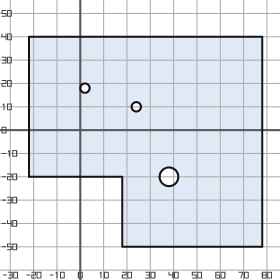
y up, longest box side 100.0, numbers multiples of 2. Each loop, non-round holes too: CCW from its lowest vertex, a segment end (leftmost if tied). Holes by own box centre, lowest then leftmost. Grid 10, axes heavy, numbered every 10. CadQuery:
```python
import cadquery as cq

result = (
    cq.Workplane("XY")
    .moveTo(18.0, -50.0)
    .lineTo(78.0, -50.0)
    .lineTo(78.0, 40.0)
    .lineTo(-22.0, 40.0)
    .lineTo(-22.0, -20.0)
    .lineTo(18.0, -20.0)
    .close()
    .moveTo(38.0, -20.0)
    .circle(4.0)
    .moveTo(24.0, 10.0)
    .circle(2.0)
    .moveTo(2.0, 18.0)
    .circle(2.0)
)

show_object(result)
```